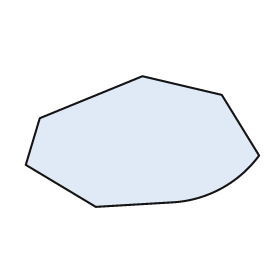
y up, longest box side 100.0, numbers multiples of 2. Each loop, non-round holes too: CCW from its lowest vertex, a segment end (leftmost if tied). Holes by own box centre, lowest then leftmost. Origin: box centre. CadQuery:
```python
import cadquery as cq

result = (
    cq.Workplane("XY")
    .moveTo(-20.0, -28.0)
    .lineTo(14.0, -26.0)
    .threePointArc((34.0, -20.0), (50.0, -6.0))
    .lineTo(34.0, 20.0)
    .lineTo(0.0, 28.0)
    .lineTo(-44.0, 10.0)
    .lineTo(-50.0, -10.0)
    .close()
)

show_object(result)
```